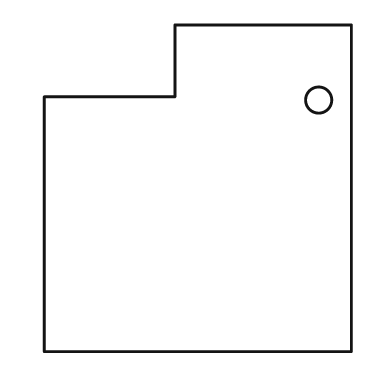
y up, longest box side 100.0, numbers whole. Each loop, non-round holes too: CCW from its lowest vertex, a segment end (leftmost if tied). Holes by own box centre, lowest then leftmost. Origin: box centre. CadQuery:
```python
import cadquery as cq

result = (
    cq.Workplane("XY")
    .moveTo(-47.0, -50.0)
    .lineTo(47.0, -50.0)
    .lineTo(47.0, 50.0)
    .lineTo(-7.0, 50.0)
    .lineTo(-7.0, 28.0)
    .lineTo(-47.0, 28.0)
    .close()
    .moveTo(37.0, 27.0)
    .circle(4.0)
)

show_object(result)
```